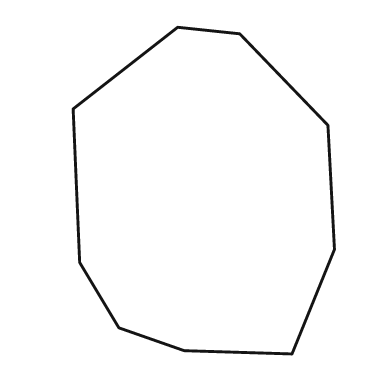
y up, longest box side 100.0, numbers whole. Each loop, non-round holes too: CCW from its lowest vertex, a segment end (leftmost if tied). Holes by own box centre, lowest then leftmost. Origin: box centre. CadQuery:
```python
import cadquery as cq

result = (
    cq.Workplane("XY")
    .moveTo(27.0, -50.0)
    .lineTo(40.0, -18.0)
    .lineTo(38.0, 20.0)
    .lineTo(11.0, 48.0)
    .lineTo(-8.0, 50.0)
    .lineTo(-40.0, 25.0)
    .lineTo(-38.0, -22.0)
    .lineTo(-26.0, -42.0)
    .lineTo(-6.0, -49.0)
    .close()
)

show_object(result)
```